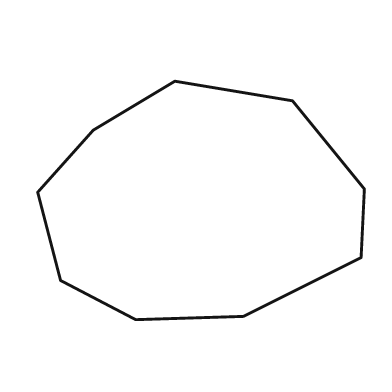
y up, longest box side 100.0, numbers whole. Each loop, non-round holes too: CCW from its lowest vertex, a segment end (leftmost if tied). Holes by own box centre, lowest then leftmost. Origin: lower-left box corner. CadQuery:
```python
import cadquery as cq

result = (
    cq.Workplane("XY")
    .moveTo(30.0, 0.0)
    .lineTo(63.0, 1.0)
    .lineTo(99.0, 19.0)
    .lineTo(100.0, 40.0)
    .lineTo(78.0, 67.0)
    .lineTo(42.0, 73.0)
    .lineTo(17.0, 58.0)
    .lineTo(0.0, 39.0)
    .lineTo(7.0, 12.0)
    .close()
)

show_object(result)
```